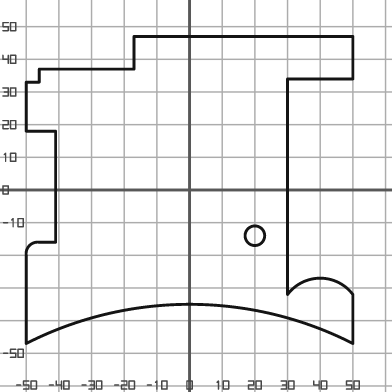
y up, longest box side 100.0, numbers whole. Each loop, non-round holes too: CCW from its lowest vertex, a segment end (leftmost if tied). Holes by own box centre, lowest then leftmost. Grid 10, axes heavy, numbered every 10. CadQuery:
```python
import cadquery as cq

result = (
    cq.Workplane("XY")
    .moveTo(-50.0, -47.0)
    .threePointArc((0.0, -35.0), (50.0, -47.0))
    .lineTo(50.0, -32.0)
    .threePointArc((40.0, -27.0), (30.0, -32.0))
    .lineTo(30.0, 34.0)
    .lineTo(50.0, 34.0)
    .lineTo(50.0, 47.0)
    .lineTo(-17.0, 47.0)
    .lineTo(-17.0, 37.0)
    .lineTo(-46.0, 37.0)
    .lineTo(-46.0, 33.0)
    .lineTo(-50.0, 33.0)
    .lineTo(-50.0, 18.0)
    .lineTo(-41.0, 18.0)
    .lineTo(-41.0, -16.0)
    .lineTo(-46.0, -16.0)
    .threePointArc((-49.0, -17.0), (-50.0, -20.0))
    .close()
    .moveTo(20.0, -14.0)
    .circle(3.0)
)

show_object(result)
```